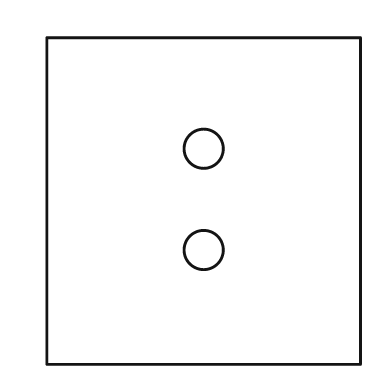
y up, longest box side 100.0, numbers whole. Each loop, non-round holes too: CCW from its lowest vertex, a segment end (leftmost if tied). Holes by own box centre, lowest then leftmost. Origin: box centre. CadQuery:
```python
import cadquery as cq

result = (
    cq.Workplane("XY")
    .moveTo(-48.0, -50.0)
    .lineTo(48.0, -50.0)
    .lineTo(48.0, 50.0)
    .lineTo(-48.0, 50.0)
    .close()
    .moveTo(0.0, -15.0)
    .circle(6.0)
    .moveTo(0.0, 16.0)
    .circle(6.0)
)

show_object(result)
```